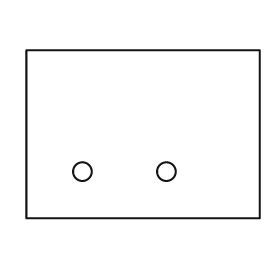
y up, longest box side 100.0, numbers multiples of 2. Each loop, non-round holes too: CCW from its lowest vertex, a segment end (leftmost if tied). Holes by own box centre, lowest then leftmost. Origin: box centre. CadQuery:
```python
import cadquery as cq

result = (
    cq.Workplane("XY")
    .moveTo(-50.0, -36.0)
    .lineTo(50.0, -36.0)
    .lineTo(50.0, 36.0)
    .lineTo(-50.0, 36.0)
    .close()
    .moveTo(-26.0, -16.0)
    .circle(4.0)
    .moveTo(10.0, -16.0)
    .circle(4.0)
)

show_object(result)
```